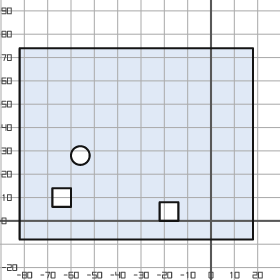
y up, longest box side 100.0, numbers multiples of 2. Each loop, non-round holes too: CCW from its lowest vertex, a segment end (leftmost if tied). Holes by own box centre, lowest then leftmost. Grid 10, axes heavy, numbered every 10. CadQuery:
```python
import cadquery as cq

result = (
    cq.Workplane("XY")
    .moveTo(-82.0, -8.0)
    .lineTo(18.0, -8.0)
    .lineTo(18.0, 74.0)
    .lineTo(-82.0, 74.0)
    .close()
    .moveTo(-22.0, 0.0)
    .lineTo(-14.0, 0.0)
    .lineTo(-14.0, 8.0)
    .lineTo(-22.0, 8.0)
    .close()
    .moveTo(-68.0, 6.0)
    .lineTo(-60.0, 6.0)
    .lineTo(-60.0, 14.0)
    .lineTo(-68.0, 14.0)
    .close()
    .moveTo(-56.0, 28.0)
    .circle(4.0)
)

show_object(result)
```